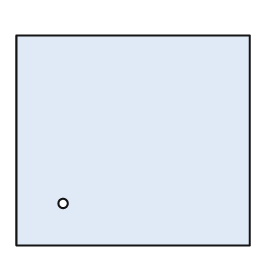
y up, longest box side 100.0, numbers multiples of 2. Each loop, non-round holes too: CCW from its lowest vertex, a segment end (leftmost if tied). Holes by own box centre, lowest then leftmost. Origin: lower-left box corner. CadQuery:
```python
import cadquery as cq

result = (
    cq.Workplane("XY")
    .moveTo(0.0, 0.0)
    .lineTo(100.0, 0.0)
    .lineTo(100.0, 90.0)
    .lineTo(0.0, 90.0)
    .close()
    .moveTo(20.0, 18.0)
    .circle(2.0)
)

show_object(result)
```